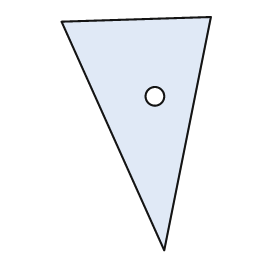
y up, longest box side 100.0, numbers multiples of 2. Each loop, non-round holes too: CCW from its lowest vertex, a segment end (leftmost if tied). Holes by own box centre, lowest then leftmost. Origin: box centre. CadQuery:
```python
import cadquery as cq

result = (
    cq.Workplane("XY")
    .moveTo(12.0, -50.0)
    .lineTo(32.0, 50.0)
    .lineTo(-32.0, 48.0)
    .close()
    .moveTo(8.0, 16.0)
    .circle(4.0)
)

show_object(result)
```